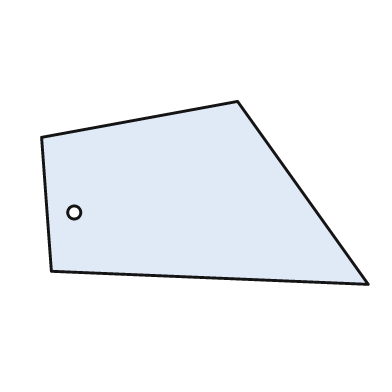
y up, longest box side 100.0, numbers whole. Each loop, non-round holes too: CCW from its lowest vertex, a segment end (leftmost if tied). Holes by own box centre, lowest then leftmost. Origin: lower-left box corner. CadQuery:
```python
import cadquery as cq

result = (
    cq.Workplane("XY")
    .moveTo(100.0, 0.0)
    .lineTo(60.0, 56.0)
    .lineTo(0.0, 45.0)
    .lineTo(3.0, 4.0)
    .close()
    .moveTo(10.0, 22.0)
    .circle(2.0)
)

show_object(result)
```